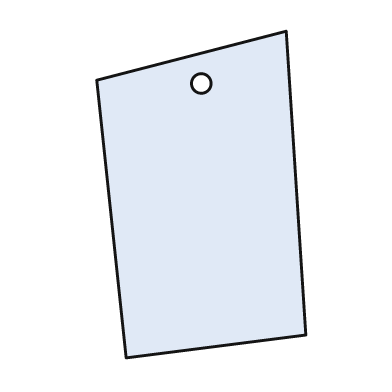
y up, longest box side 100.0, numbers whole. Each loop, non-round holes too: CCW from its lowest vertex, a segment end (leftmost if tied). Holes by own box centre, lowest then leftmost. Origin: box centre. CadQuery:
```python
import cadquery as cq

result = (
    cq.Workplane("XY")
    .moveTo(-23.0, -50.0)
    .lineTo(32.0, -43.0)
    .lineTo(26.0, 50.0)
    .lineTo(-32.0, 35.0)
    .close()
    .moveTo(0.0, 34.0)
    .circle(3.0)
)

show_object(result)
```